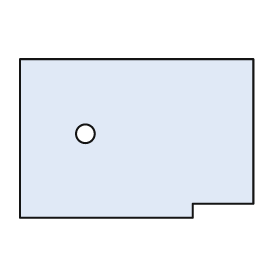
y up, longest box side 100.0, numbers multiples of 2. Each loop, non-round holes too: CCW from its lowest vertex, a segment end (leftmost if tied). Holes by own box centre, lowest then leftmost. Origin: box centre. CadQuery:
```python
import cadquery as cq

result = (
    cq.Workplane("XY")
    .moveTo(-50.0, -34.0)
    .lineTo(24.0, -34.0)
    .lineTo(24.0, -28.0)
    .lineTo(50.0, -28.0)
    .lineTo(50.0, 34.0)
    .lineTo(-50.0, 34.0)
    .close()
    .moveTo(-22.0, 2.0)
    .circle(4.0)
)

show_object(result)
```